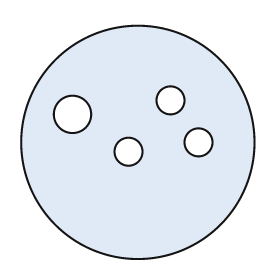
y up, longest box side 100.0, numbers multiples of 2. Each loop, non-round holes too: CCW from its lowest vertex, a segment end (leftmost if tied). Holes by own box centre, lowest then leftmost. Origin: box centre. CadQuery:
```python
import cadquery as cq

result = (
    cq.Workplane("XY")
    .moveTo(0.0, 0.0)
    .circle(50.0)
    .moveTo(-4.0, -4.0)
    .circle(6.0)
    .moveTo(26.0, 0.0)
    .circle(6.0)
    .moveTo(-28.0, 12.0)
    .circle(8.0)
    .moveTo(14.0, 18.0)
    .circle(6.0)
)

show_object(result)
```